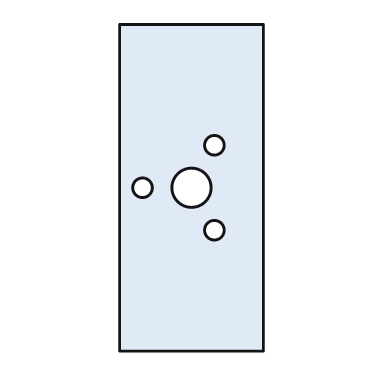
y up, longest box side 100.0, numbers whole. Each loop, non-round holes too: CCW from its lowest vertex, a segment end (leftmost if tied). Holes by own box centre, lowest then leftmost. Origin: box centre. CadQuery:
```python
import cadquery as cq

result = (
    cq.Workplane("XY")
    .moveTo(-22.0, -50.0)
    .lineTo(22.0, -50.0)
    .lineTo(22.0, 50.0)
    .lineTo(-22.0, 50.0)
    .close()
    .moveTo(7.0, -13.0)
    .circle(3.0)
    .moveTo(-15.0, 0.0)
    .circle(3.0)
    .moveTo(0.0, 0.0)
    .circle(6.0)
    .moveTo(7.0, 13.0)
    .circle(3.0)
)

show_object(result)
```